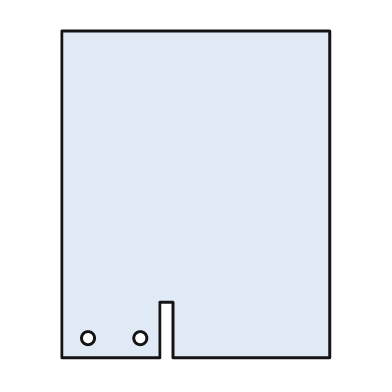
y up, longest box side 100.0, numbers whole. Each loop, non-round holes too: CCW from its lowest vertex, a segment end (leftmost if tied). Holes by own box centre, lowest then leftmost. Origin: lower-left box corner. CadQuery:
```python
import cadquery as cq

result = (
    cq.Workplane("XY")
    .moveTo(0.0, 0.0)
    .lineTo(30.0, 0.0)
    .lineTo(30.0, 17.0)
    .lineTo(34.0, 17.0)
    .lineTo(34.0, 0.0)
    .lineTo(82.0, 0.0)
    .lineTo(82.0, 100.0)
    .lineTo(0.0, 100.0)
    .close()
    .moveTo(8.0, 6.0)
    .circle(2.0)
    .moveTo(24.0, 6.0)
    .circle(2.0)
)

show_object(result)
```